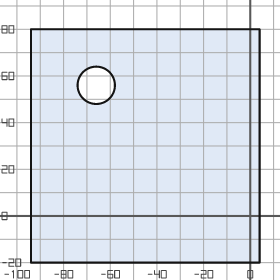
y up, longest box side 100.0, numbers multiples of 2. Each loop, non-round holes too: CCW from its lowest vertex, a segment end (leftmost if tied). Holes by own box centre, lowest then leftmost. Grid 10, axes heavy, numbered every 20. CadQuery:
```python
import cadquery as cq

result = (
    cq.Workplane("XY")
    .moveTo(-94.0, -20.0)
    .lineTo(4.0, -20.0)
    .lineTo(4.0, 80.0)
    .lineTo(-94.0, 80.0)
    .close()
    .moveTo(-66.0, 56.0)
    .circle(8.0)
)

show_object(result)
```